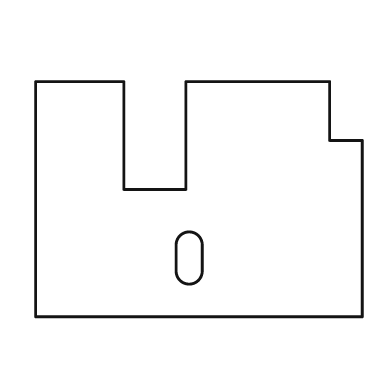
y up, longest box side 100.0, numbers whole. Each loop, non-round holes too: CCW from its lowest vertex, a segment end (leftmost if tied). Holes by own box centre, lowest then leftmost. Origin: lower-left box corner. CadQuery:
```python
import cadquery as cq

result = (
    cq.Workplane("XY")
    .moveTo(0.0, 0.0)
    .lineTo(100.0, 0.0)
    .lineTo(100.0, 54.0)
    .lineTo(90.0, 54.0)
    .lineTo(90.0, 72.0)
    .lineTo(46.0, 72.0)
    .lineTo(46.0, 39.0)
    .lineTo(27.0, 39.0)
    .lineTo(27.0, 72.0)
    .lineTo(0.0, 72.0)
    .close()
    .moveTo(43.0, 14.0)
    .threePointArc((47.0, 10.0), (51.0, 14.0))
    .lineTo(51.0, 22.0)
    .threePointArc((47.0, 26.0), (43.0, 22.0))
    .close()
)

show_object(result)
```